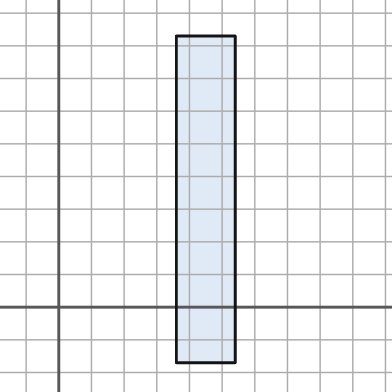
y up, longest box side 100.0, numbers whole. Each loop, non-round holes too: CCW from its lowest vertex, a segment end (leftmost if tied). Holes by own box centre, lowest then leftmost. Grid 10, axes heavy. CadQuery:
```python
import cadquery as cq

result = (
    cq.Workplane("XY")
    .moveTo(36.0, -17.0)
    .lineTo(54.0, -17.0)
    .lineTo(54.0, 83.0)
    .lineTo(36.0, 83.0)
    .close()
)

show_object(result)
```